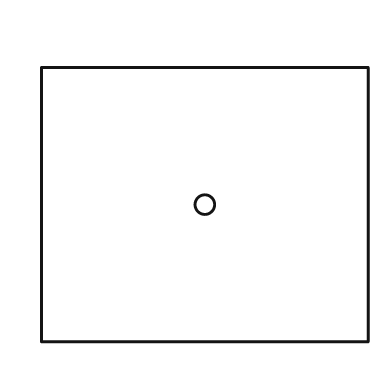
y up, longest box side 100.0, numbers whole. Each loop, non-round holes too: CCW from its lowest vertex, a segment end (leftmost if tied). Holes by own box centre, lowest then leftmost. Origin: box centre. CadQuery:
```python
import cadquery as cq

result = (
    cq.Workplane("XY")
    .moveTo(-50.0, -42.0)
    .lineTo(50.0, -42.0)
    .lineTo(50.0, 42.0)
    .lineTo(-50.0, 42.0)
    .close()
    .moveTo(0.0, 0.0)
    .circle(3.0)
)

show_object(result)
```